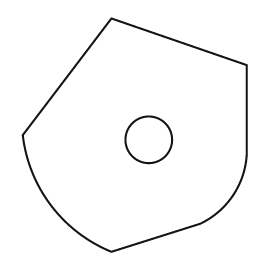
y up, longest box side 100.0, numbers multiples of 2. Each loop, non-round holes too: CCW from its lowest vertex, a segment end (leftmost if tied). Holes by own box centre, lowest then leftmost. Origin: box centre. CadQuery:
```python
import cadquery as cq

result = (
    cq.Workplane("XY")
    .moveTo(-10.0, -50.0)
    .lineTo(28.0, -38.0)
    .threePointArc((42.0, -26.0), (48.0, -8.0))
    .lineTo(48.0, 30.0)
    .lineTo(-10.0, 50.0)
    .lineTo(-48.0, 0.0)
    .threePointArc((-36.0, -30.0), (-10.0, -50.0))
    .close()
    .moveTo(6.0, -2.0)
    .circle(10.0)
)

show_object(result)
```